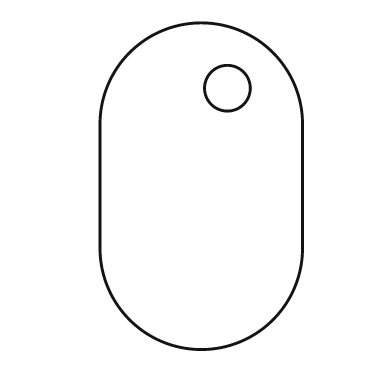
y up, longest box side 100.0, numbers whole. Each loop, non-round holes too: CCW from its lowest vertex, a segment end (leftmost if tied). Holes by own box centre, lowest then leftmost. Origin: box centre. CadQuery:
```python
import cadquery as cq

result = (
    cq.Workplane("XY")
    .moveTo(-31.0, -19.0)
    .threePointArc((0.0, -50.0), (31.0, -19.0))
    .lineTo(31.0, 19.0)
    .threePointArc((0.0, 50.0), (-31.0, 19.0))
    .close()
    .moveTo(8.0, 30.0)
    .circle(7.0)
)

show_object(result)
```